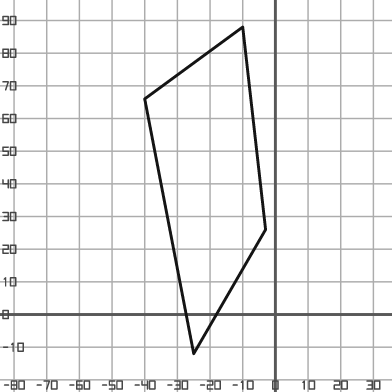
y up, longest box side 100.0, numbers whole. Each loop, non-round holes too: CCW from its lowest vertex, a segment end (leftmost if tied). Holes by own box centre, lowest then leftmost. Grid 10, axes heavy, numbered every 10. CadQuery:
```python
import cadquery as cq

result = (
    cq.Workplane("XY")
    .moveTo(-25.0, -12.0)
    .lineTo(-3.0, 26.0)
    .lineTo(-10.0, 88.0)
    .lineTo(-40.0, 66.0)
    .close()
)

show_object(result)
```